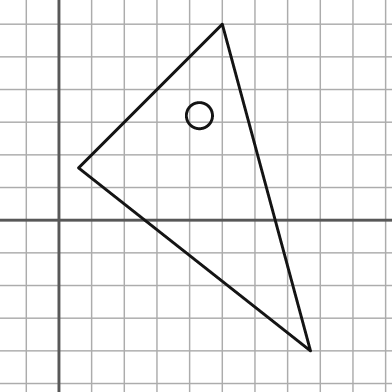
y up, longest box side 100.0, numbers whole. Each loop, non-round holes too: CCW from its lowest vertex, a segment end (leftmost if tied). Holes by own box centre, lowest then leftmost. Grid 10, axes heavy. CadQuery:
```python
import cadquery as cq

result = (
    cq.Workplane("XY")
    .moveTo(77.0, -40.0)
    .lineTo(50.0, 60.0)
    .lineTo(6.0, 16.0)
    .close()
    .moveTo(43.0, 32.0)
    .circle(4.0)
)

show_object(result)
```